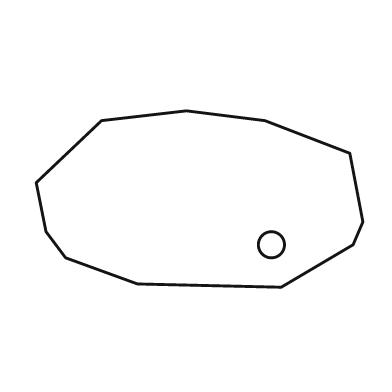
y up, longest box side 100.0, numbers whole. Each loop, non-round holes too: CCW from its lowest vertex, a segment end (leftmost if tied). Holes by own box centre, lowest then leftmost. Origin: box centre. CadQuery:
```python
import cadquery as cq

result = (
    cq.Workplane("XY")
    .moveTo(25.0, -27.0)
    .lineTo(47.0, -14.0)
    .lineTo(50.0, -7.0)
    .lineTo(46.0, 14.0)
    .lineTo(20.0, 24.0)
    .lineTo(-4.0, 27.0)
    .lineTo(-30.0, 24.0)
    .lineTo(-50.0, 5.0)
    .lineTo(-47.0, -10.0)
    .lineTo(-41.0, -18.0)
    .lineTo(-19.0, -26.0)
    .close()
    .moveTo(22.0, -14.0)
    .circle(4.0)
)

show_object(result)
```